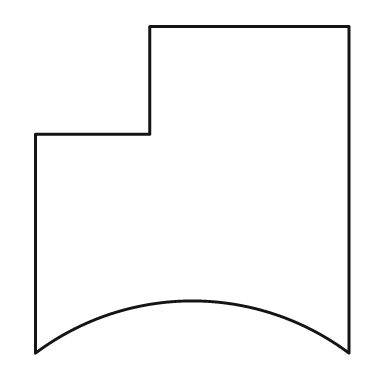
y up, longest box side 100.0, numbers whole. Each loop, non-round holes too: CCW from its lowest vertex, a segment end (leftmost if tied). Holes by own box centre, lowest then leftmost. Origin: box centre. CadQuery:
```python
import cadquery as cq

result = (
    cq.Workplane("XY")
    .moveTo(-48.0, -50.0)
    .threePointArc((0.0, -34.0), (48.0, -50.0))
    .lineTo(48.0, 50.0)
    .lineTo(-13.0, 50.0)
    .lineTo(-13.0, 17.0)
    .lineTo(-48.0, 17.0)
    .close()
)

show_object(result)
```